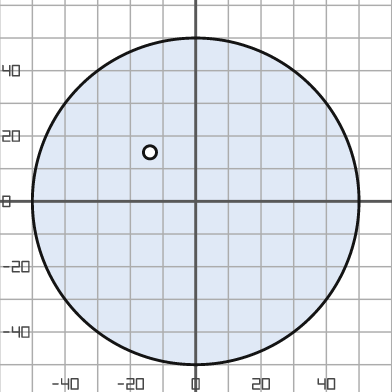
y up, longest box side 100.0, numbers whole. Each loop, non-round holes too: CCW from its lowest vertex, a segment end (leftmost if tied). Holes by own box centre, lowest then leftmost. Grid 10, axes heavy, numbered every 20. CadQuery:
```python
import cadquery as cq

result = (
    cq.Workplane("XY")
    .moveTo(0.0, 0.0)
    .circle(50.0)
    .moveTo(-14.0, 15.0)
    .circle(2.0)
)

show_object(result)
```